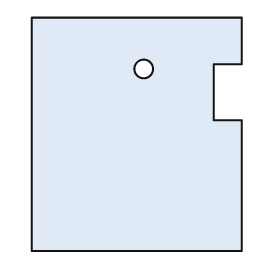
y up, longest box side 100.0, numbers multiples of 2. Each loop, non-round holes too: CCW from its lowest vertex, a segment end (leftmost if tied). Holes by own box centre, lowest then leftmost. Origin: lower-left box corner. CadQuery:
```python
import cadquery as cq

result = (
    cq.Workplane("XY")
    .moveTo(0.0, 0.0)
    .lineTo(90.0, 0.0)
    .lineTo(90.0, 56.0)
    .lineTo(78.0, 56.0)
    .lineTo(78.0, 80.0)
    .lineTo(90.0, 80.0)
    .lineTo(90.0, 100.0)
    .lineTo(0.0, 100.0)
    .close()
    .moveTo(48.0, 78.0)
    .circle(4.0)
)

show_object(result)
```